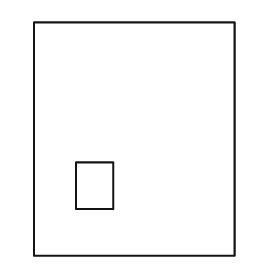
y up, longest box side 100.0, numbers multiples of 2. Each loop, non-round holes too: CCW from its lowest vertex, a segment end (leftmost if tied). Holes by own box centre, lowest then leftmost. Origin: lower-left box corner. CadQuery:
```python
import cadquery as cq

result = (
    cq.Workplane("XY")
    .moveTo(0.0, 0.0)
    .lineTo(86.0, 0.0)
    .lineTo(86.0, 100.0)
    .lineTo(0.0, 100.0)
    .close()
    .moveTo(18.0, 20.0)
    .lineTo(34.0, 20.0)
    .lineTo(34.0, 40.0)
    .lineTo(18.0, 40.0)
    .close()
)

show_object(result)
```